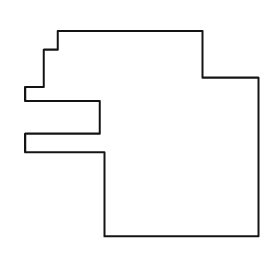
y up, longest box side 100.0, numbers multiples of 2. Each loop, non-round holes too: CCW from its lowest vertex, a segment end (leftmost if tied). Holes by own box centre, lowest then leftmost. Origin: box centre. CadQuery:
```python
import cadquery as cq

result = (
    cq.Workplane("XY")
    .moveTo(-16.0, -44.0)
    .lineTo(50.0, -44.0)
    .lineTo(50.0, 24.0)
    .lineTo(26.0, 24.0)
    .lineTo(26.0, 44.0)
    .lineTo(-36.0, 44.0)
    .lineTo(-36.0, 36.0)
    .lineTo(-42.0, 36.0)
    .lineTo(-42.0, 20.0)
    .lineTo(-50.0, 20.0)
    .lineTo(-50.0, 14.0)
    .lineTo(-18.0, 14.0)
    .lineTo(-18.0, 0.0)
    .lineTo(-50.0, 0.0)
    .lineTo(-50.0, -8.0)
    .lineTo(-16.0, -8.0)
    .close()
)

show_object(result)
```